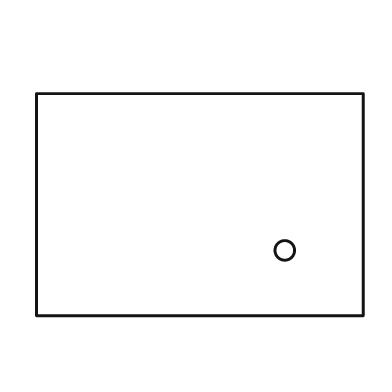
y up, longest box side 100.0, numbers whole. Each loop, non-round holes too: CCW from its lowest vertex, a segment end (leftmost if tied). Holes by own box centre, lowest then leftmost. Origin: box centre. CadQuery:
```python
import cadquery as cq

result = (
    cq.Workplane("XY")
    .moveTo(-50.0, -34.0)
    .lineTo(50.0, -34.0)
    .lineTo(50.0, 34.0)
    .lineTo(-50.0, 34.0)
    .close()
    .moveTo(26.0, -14.0)
    .circle(3.0)
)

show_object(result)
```